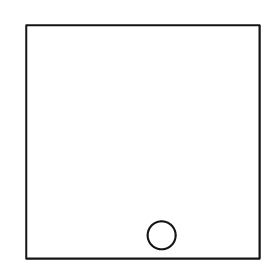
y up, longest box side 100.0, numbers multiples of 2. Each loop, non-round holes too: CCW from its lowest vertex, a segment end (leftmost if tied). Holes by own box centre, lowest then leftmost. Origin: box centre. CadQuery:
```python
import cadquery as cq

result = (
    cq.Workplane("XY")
    .moveTo(-50.0, -50.0)
    .lineTo(50.0, -50.0)
    .lineTo(50.0, 50.0)
    .lineTo(-50.0, 50.0)
    .close()
    .moveTo(8.0, -40.0)
    .circle(6.0)
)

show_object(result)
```